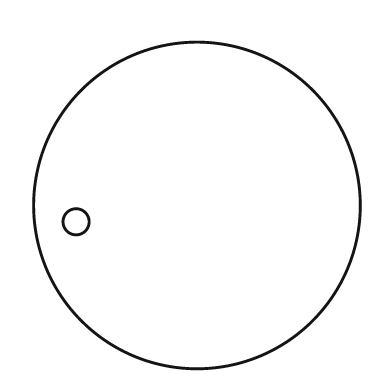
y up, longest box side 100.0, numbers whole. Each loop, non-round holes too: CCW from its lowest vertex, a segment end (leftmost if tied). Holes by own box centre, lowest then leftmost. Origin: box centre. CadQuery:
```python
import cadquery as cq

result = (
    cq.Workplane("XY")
    .moveTo(0.0, 0.0)
    .circle(50.0)
    .moveTo(-37.0, -5.0)
    .circle(4.0)
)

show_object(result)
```